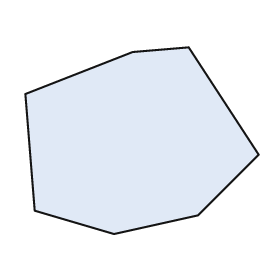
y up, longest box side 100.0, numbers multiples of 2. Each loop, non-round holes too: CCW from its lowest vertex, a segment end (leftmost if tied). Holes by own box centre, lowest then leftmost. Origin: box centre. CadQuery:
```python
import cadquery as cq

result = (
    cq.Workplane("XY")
    .moveTo(-12.0, -40.0)
    .lineTo(24.0, -32.0)
    .lineTo(50.0, -6.0)
    .lineTo(20.0, 40.0)
    .lineTo(-4.0, 38.0)
    .lineTo(-50.0, 20.0)
    .lineTo(-46.0, -30.0)
    .close()
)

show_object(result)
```